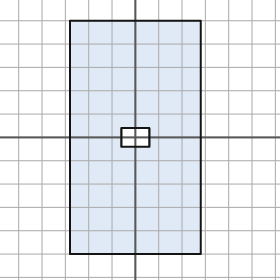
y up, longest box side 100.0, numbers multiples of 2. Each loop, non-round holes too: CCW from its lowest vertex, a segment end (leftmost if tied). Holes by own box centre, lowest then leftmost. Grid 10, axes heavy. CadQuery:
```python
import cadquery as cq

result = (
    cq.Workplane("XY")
    .moveTo(-28.0, -50.0)
    .lineTo(28.0, -50.0)
    .lineTo(28.0, 50.0)
    .lineTo(-28.0, 50.0)
    .close()
    .moveTo(-6.0, -4.0)
    .lineTo(6.0, -4.0)
    .lineTo(6.0, 4.0)
    .lineTo(-6.0, 4.0)
    .close()
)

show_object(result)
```